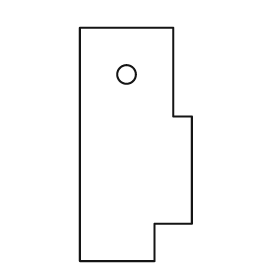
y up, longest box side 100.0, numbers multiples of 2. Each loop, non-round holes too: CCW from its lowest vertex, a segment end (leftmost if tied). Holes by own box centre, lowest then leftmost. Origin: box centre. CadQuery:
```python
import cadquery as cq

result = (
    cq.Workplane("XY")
    .moveTo(-24.0, -50.0)
    .lineTo(8.0, -50.0)
    .lineTo(8.0, -34.0)
    .lineTo(24.0, -34.0)
    .lineTo(24.0, 12.0)
    .lineTo(16.0, 12.0)
    .lineTo(16.0, 50.0)
    .lineTo(-24.0, 50.0)
    .close()
    .moveTo(-4.0, 30.0)
    .circle(4.0)
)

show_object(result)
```